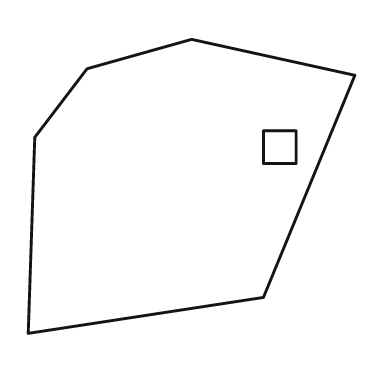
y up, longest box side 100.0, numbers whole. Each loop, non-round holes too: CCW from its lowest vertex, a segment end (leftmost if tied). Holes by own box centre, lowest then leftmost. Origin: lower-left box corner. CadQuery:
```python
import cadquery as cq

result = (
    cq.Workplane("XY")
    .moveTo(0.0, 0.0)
    .lineTo(72.0, 11.0)
    .lineTo(100.0, 79.0)
    .lineTo(50.0, 90.0)
    .lineTo(18.0, 81.0)
    .lineTo(2.0, 60.0)
    .close()
    .moveTo(72.0, 52.0)
    .lineTo(82.0, 52.0)
    .lineTo(82.0, 62.0)
    .lineTo(72.0, 62.0)
    .close()
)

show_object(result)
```